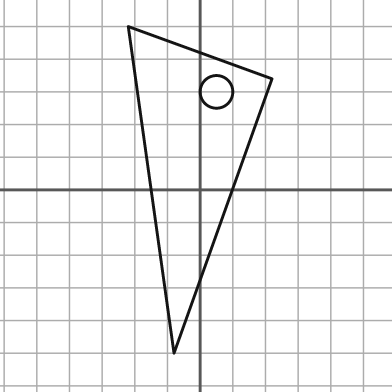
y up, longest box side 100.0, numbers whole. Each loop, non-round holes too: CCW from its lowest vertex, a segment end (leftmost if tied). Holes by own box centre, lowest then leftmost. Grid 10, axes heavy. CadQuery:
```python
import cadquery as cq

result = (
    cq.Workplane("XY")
    .moveTo(-8.0, -50.0)
    .lineTo(22.0, 34.0)
    .lineTo(-22.0, 50.0)
    .close()
    .moveTo(5.0, 30.0)
    .circle(5.0)
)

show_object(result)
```